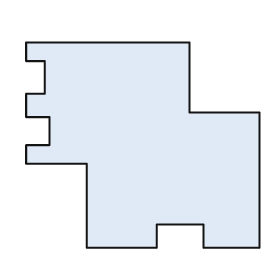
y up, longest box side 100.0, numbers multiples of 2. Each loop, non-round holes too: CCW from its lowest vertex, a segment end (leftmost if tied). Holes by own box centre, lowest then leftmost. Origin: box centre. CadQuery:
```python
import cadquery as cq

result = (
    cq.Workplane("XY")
    .moveTo(-24.0, -44.0)
    .lineTo(6.0, -44.0)
    .lineTo(6.0, -34.0)
    .lineTo(26.0, -34.0)
    .lineTo(26.0, -44.0)
    .lineTo(50.0, -44.0)
    .lineTo(50.0, 14.0)
    .lineTo(20.0, 14.0)
    .lineTo(20.0, 44.0)
    .lineTo(-50.0, 44.0)
    .lineTo(-50.0, 36.0)
    .lineTo(-42.0, 36.0)
    .lineTo(-42.0, 22.0)
    .lineTo(-50.0, 22.0)
    .lineTo(-50.0, 12.0)
    .lineTo(-40.0, 12.0)
    .lineTo(-40.0, 0.0)
    .lineTo(-50.0, 0.0)
    .lineTo(-50.0, -8.0)
    .lineTo(-24.0, -8.0)
    .close()
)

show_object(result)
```